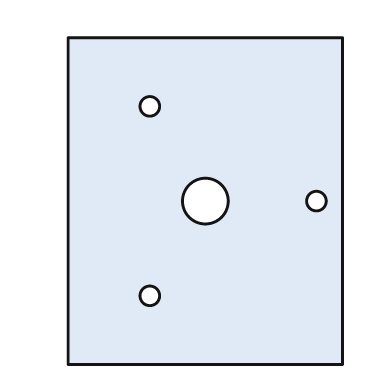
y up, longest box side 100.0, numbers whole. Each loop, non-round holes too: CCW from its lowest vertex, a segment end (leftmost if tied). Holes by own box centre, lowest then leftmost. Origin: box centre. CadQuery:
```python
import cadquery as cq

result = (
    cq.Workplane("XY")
    .moveTo(-42.0, -50.0)
    .lineTo(42.0, -50.0)
    .lineTo(42.0, 50.0)
    .lineTo(-42.0, 50.0)
    .close()
    .moveTo(-17.0, -29.0)
    .circle(3.0)
    .moveTo(0.0, 0.0)
    .circle(7.0)
    .moveTo(34.0, 0.0)
    .circle(3.0)
    .moveTo(-17.0, 29.0)
    .circle(3.0)
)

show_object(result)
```